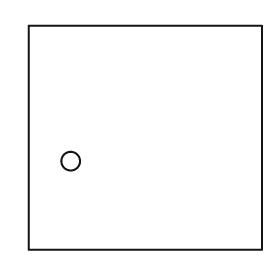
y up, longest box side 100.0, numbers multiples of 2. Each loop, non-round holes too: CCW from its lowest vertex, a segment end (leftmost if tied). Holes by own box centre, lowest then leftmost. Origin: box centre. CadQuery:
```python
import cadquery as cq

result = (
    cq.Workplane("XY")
    .moveTo(-50.0, -48.0)
    .lineTo(50.0, -48.0)
    .lineTo(50.0, 48.0)
    .lineTo(-50.0, 48.0)
    .close()
    .moveTo(-32.0, -10.0)
    .circle(4.0)
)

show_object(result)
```